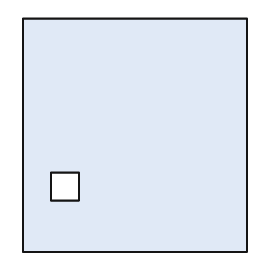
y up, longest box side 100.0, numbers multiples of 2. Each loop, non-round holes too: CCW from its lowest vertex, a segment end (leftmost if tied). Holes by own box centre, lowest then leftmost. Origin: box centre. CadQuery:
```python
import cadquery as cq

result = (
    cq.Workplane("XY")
    .moveTo(-48.0, -50.0)
    .lineTo(48.0, -50.0)
    .lineTo(48.0, 50.0)
    .lineTo(-48.0, 50.0)
    .close()
    .moveTo(-36.0, -28.0)
    .lineTo(-24.0, -28.0)
    .lineTo(-24.0, -16.0)
    .lineTo(-36.0, -16.0)
    .close()
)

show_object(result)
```